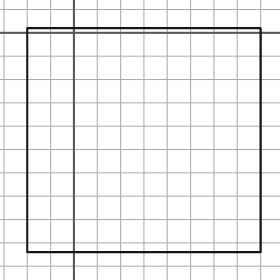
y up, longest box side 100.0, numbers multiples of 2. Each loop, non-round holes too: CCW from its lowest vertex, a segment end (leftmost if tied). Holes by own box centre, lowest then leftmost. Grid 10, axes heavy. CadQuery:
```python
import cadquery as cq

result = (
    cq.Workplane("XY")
    .moveTo(-20.0, -94.0)
    .lineTo(80.0, -94.0)
    .lineTo(80.0, 2.0)
    .lineTo(-20.0, 2.0)
    .close()
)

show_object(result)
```